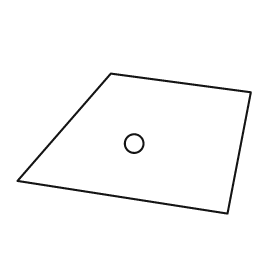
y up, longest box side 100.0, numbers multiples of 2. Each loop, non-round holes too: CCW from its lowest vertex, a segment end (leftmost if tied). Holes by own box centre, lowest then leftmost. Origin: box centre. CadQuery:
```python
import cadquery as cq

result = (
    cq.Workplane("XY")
    .moveTo(40.0, -30.0)
    .lineTo(50.0, 22.0)
    .lineTo(-10.0, 30.0)
    .lineTo(-50.0, -16.0)
    .close()
    .moveTo(0.0, 0.0)
    .circle(4.0)
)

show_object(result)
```